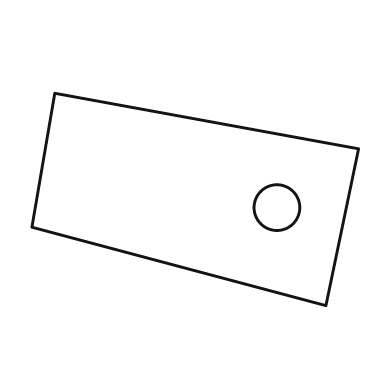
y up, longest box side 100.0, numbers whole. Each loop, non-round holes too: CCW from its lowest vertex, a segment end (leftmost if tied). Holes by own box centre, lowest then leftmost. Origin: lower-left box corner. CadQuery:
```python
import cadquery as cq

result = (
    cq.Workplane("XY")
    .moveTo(90.0, 0.0)
    .lineTo(100.0, 48.0)
    .lineTo(7.0, 65.0)
    .lineTo(0.0, 24.0)
    .close()
    .moveTo(75.0, 30.0)
    .circle(7.0)
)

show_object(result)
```